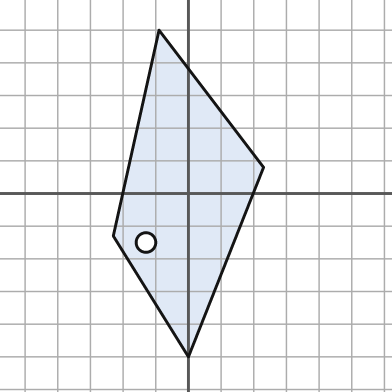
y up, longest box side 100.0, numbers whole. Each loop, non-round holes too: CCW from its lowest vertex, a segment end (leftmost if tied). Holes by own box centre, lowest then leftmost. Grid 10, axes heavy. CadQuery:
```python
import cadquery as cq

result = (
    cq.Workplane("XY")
    .moveTo(0.0, -50.0)
    .lineTo(23.0, 8.0)
    .lineTo(-9.0, 50.0)
    .lineTo(-23.0, -13.0)
    .close()
    .moveTo(-13.0, -15.0)
    .circle(3.0)
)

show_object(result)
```